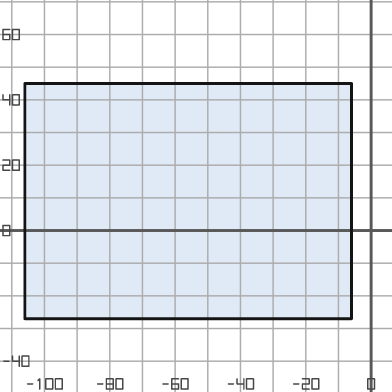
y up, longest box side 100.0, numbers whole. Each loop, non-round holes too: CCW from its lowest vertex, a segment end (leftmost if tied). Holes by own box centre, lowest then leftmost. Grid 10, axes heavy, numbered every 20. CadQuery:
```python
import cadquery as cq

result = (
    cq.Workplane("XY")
    .moveTo(-106.0, -27.0)
    .lineTo(-6.0, -27.0)
    .lineTo(-6.0, 45.0)
    .lineTo(-106.0, 45.0)
    .close()
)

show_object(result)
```